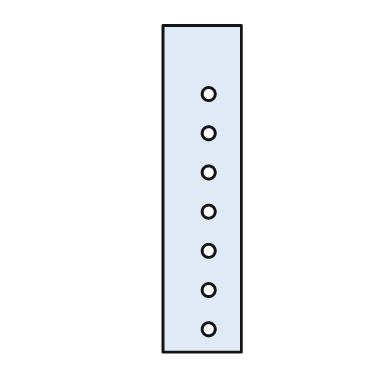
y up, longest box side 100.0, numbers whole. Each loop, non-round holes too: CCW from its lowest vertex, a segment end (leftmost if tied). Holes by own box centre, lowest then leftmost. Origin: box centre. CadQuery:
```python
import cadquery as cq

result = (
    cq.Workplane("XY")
    .moveTo(-12.0, -50.0)
    .lineTo(12.0, -50.0)
    .lineTo(12.0, 50.0)
    .lineTo(-12.0, 50.0)
    .close()
    .moveTo(2.0, -43.0)
    .circle(2.0)
    .moveTo(2.0, -31.0)
    .circle(2.0)
    .moveTo(2.0, -19.0)
    .circle(2.0)
    .moveTo(2.0, -7.0)
    .circle(2.0)
    .moveTo(2.0, 5.0)
    .circle(2.0)
    .moveTo(2.0, 17.0)
    .circle(2.0)
    .moveTo(2.0, 29.0)
    .circle(2.0)
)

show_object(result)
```